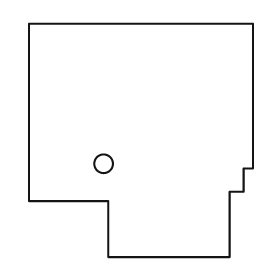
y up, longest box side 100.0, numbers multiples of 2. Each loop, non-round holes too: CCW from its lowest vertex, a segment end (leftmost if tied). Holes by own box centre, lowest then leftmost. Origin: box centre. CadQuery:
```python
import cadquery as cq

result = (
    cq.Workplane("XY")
    .moveTo(-14.0, -50.0)
    .lineTo(38.0, -50.0)
    .lineTo(38.0, -22.0)
    .lineTo(44.0, -22.0)
    .lineTo(44.0, -12.0)
    .lineTo(48.0, -12.0)
    .lineTo(48.0, 50.0)
    .lineTo(-48.0, 50.0)
    .lineTo(-48.0, -26.0)
    .lineTo(-14.0, -26.0)
    .close()
    .moveTo(-16.0, -10.0)
    .circle(4.0)
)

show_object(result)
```